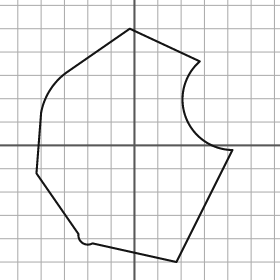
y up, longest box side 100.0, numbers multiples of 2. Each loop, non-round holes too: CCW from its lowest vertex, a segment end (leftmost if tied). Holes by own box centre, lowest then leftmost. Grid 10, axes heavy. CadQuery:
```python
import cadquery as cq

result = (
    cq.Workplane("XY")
    .moveTo(18.0, -50.0)
    .lineTo(42.0, -2.0)
    .threePointArc((22.0, 12.0), (28.0, 36.0))
    .lineTo(-2.0, 50.0)
    .lineTo(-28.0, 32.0)
    .threePointArc((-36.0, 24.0), (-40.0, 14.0))
    .lineTo(-42.0, -12.0)
    .lineTo(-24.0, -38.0)
    .threePointArc((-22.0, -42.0), (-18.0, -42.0))
    .close()
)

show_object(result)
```